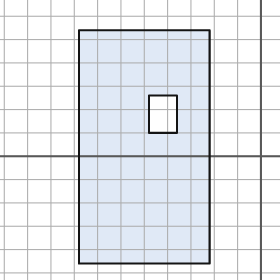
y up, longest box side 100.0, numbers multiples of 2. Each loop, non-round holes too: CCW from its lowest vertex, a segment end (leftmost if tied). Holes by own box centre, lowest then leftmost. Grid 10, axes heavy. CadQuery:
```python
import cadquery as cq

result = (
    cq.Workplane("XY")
    .moveTo(-78.0, -46.0)
    .lineTo(-22.0, -46.0)
    .lineTo(-22.0, 54.0)
    .lineTo(-78.0, 54.0)
    .close()
    .moveTo(-48.0, 10.0)
    .lineTo(-36.0, 10.0)
    .lineTo(-36.0, 26.0)
    .lineTo(-48.0, 26.0)
    .close()
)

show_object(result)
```